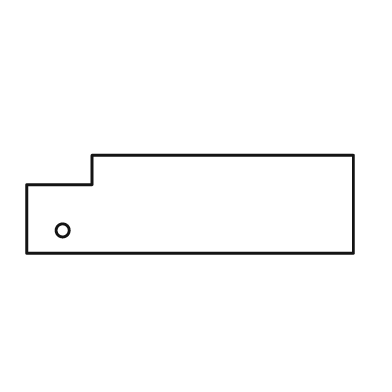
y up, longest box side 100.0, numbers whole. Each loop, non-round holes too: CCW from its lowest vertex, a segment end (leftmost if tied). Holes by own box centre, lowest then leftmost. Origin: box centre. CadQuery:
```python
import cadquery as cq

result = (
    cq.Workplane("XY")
    .moveTo(-50.0, -15.0)
    .lineTo(50.0, -15.0)
    .lineTo(50.0, 15.0)
    .lineTo(-30.0, 15.0)
    .lineTo(-30.0, 6.0)
    .lineTo(-50.0, 6.0)
    .close()
    .moveTo(-39.0, -8.0)
    .circle(2.0)
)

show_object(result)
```